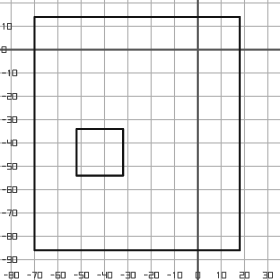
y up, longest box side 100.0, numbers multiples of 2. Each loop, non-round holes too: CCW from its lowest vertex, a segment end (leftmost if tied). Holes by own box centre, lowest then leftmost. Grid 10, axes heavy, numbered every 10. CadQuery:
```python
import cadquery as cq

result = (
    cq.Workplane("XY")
    .moveTo(-70.0, -86.0)
    .lineTo(18.0, -86.0)
    .lineTo(18.0, 14.0)
    .lineTo(-70.0, 14.0)
    .close()
    .moveTo(-52.0, -54.0)
    .lineTo(-32.0, -54.0)
    .lineTo(-32.0, -34.0)
    .lineTo(-52.0, -34.0)
    .close()
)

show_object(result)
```